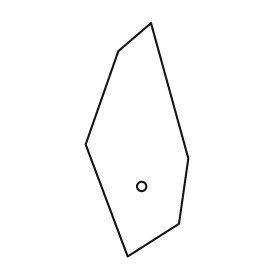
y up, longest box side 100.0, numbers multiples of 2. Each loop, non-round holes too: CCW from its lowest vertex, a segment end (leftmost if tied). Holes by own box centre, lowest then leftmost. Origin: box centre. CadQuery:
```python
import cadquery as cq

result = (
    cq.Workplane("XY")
    .moveTo(-4.0, -50.0)
    .lineTo(18.0, -36.0)
    .lineTo(22.0, -8.0)
    .lineTo(6.0, 50.0)
    .lineTo(-8.0, 38.0)
    .lineTo(-22.0, -2.0)
    .close()
    .moveTo(2.0, -20.0)
    .circle(2.0)
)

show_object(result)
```